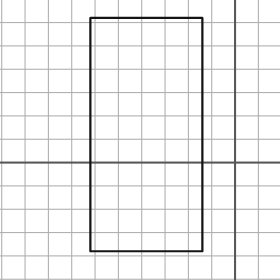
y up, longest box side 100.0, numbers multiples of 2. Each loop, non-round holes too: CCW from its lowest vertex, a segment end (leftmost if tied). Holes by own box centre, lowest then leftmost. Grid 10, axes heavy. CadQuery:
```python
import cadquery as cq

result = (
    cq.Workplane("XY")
    .moveTo(-62.0, -38.0)
    .lineTo(-14.0, -38.0)
    .lineTo(-14.0, 62.0)
    .lineTo(-62.0, 62.0)
    .close()
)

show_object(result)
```